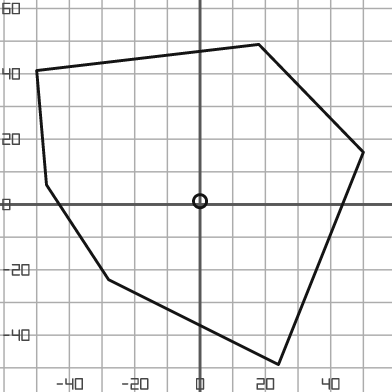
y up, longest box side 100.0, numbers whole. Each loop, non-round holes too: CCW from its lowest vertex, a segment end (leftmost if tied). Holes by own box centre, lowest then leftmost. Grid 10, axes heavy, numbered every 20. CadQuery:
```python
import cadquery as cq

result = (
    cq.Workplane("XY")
    .moveTo(24.0, -49.0)
    .lineTo(50.0, 16.0)
    .lineTo(18.0, 49.0)
    .lineTo(-50.0, 41.0)
    .lineTo(-47.0, 6.0)
    .lineTo(-28.0, -23.0)
    .close()
    .moveTo(0.0, 1.0)
    .circle(2.0)
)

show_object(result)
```